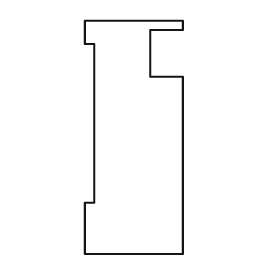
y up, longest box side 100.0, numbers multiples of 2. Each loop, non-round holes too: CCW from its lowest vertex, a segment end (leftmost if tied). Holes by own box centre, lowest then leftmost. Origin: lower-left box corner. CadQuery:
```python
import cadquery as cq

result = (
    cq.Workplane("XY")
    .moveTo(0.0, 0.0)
    .lineTo(42.0, 0.0)
    .lineTo(42.0, 76.0)
    .lineTo(28.0, 76.0)
    .lineTo(28.0, 96.0)
    .lineTo(42.0, 96.0)
    .lineTo(42.0, 100.0)
    .lineTo(0.0, 100.0)
    .lineTo(0.0, 90.0)
    .lineTo(4.0, 90.0)
    .lineTo(4.0, 22.0)
    .lineTo(0.0, 22.0)
    .close()
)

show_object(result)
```